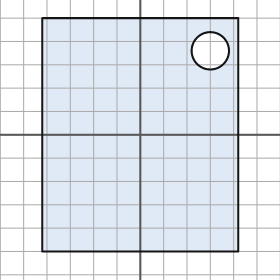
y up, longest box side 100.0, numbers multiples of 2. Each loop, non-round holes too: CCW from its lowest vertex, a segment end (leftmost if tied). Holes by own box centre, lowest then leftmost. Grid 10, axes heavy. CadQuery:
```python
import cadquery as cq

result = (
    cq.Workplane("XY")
    .moveTo(-42.0, -50.0)
    .lineTo(42.0, -50.0)
    .lineTo(42.0, 50.0)
    .lineTo(-42.0, 50.0)
    .close()
    .moveTo(30.0, 36.0)
    .circle(8.0)
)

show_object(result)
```